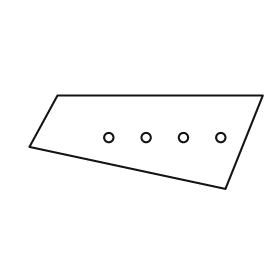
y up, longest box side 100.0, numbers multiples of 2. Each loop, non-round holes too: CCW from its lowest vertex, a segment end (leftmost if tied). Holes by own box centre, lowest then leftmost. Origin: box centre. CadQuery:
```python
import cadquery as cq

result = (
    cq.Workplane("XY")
    .moveTo(34.0, -20.0)
    .lineTo(50.0, 20.0)
    .lineTo(-38.0, 20.0)
    .lineTo(-50.0, -2.0)
    .close()
    .moveTo(-16.0, 2.0)
    .circle(2.0)
    .moveTo(0.0, 2.0)
    .circle(2.0)
    .moveTo(16.0, 2.0)
    .circle(2.0)
    .moveTo(32.0, 2.0)
    .circle(2.0)
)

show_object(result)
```